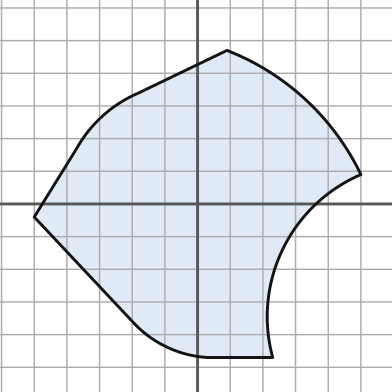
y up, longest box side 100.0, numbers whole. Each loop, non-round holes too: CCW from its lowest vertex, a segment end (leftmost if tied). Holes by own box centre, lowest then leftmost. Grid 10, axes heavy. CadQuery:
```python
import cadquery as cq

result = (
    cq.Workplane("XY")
    .moveTo(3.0, -47.0)
    .lineTo(23.0, -47.0)
    .threePointArc((26.0, -14.0), (50.0, 9.0))
    .threePointArc((33.0, 32.0), (9.0, 47.0))
    .lineTo(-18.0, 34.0)
    .threePointArc((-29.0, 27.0), (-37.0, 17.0))
    .lineTo(-50.0, -4.0)
    .lineTo(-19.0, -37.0)
    .threePointArc((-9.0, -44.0), (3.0, -47.0))
    .close()
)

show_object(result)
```